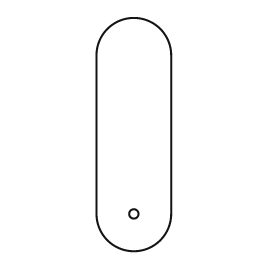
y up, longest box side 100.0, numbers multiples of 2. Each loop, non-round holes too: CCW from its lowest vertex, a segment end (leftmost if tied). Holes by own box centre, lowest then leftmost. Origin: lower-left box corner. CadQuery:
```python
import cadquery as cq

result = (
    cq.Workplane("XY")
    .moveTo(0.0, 16.0)
    .threePointArc((16.0, 0.0), (32.0, 16.0))
    .lineTo(32.0, 84.0)
    .threePointArc((16.0, 100.0), (0.0, 84.0))
    .close()
    .moveTo(16.0, 16.0)
    .circle(2.0)
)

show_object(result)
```